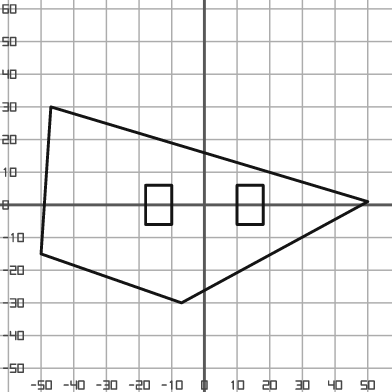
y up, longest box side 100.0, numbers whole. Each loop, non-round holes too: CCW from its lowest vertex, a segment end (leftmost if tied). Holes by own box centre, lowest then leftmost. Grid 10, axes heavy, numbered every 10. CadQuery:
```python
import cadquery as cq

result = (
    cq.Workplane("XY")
    .moveTo(-7.0, -30.0)
    .lineTo(50.0, 1.0)
    .lineTo(-47.0, 30.0)
    .lineTo(-50.0, -15.0)
    .close()
    .moveTo(-18.0, -6.0)
    .lineTo(-10.0, -6.0)
    .lineTo(-10.0, 6.0)
    .lineTo(-18.0, 6.0)
    .close()
    .moveTo(10.0, -6.0)
    .lineTo(18.0, -6.0)
    .lineTo(18.0, 6.0)
    .lineTo(10.0, 6.0)
    .close()
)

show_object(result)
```